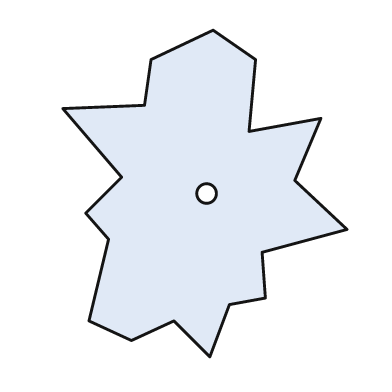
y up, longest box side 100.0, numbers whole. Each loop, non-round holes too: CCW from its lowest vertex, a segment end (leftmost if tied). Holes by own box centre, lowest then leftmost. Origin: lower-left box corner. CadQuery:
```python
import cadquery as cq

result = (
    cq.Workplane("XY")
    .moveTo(45.0, 0.0)
    .lineTo(51.0, 16.0)
    .lineTo(62.0, 18.0)
    .lineTo(61.0, 32.0)
    .lineTo(87.0, 39.0)
    .lineTo(71.0, 54.0)
    .lineTo(79.0, 73.0)
    .lineTo(57.0, 69.0)
    .lineTo(59.0, 91.0)
    .lineTo(46.0, 100.0)
    .lineTo(27.0, 91.0)
    .lineTo(25.0, 77.0)
    .lineTo(0.0, 76.0)
    .lineTo(18.0, 55.0)
    .lineTo(7.0, 44.0)
    .lineTo(14.0, 36.0)
    .lineTo(8.0, 11.0)
    .lineTo(21.0, 5.0)
    .lineTo(34.0, 11.0)
    .close()
    .moveTo(44.0, 50.0)
    .circle(3.0)
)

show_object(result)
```